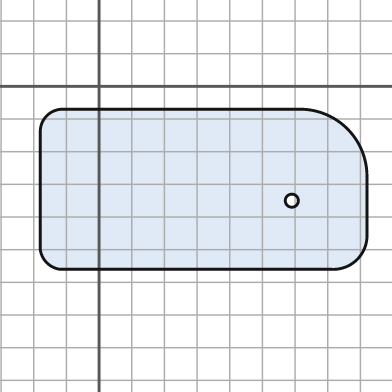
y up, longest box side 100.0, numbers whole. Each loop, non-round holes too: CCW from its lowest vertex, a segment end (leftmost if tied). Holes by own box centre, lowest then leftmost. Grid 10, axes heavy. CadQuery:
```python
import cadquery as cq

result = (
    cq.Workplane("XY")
    .moveTo(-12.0, -56.0)
    .lineTo(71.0, -56.0)
    .threePointArc((79.0, -53.0), (82.0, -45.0))
    .lineTo(82.0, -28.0)
    .threePointArc((76.0, -13.0), (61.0, -7.0))
    .lineTo(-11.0, -7.0)
    .threePointArc((-16.0, -9.0), (-18.0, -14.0))
    .lineTo(-18.0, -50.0)
    .threePointArc((-16.0, -54.0), (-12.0, -56.0))
    .close()
    .moveTo(59.0, -35.0)
    .circle(2.0)
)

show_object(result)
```